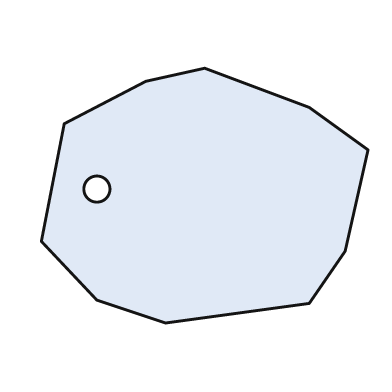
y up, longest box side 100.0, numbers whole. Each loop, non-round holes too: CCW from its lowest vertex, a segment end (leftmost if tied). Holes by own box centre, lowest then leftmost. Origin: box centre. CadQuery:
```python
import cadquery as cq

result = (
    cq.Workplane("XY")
    .moveTo(-12.0, -39.0)
    .lineTo(32.0, -33.0)
    .lineTo(43.0, -17.0)
    .lineTo(50.0, 14.0)
    .lineTo(32.0, 27.0)
    .lineTo(0.0, 39.0)
    .lineTo(-18.0, 35.0)
    .lineTo(-43.0, 22.0)
    .lineTo(-50.0, -14.0)
    .lineTo(-33.0, -32.0)
    .close()
    .moveTo(-33.0, 2.0)
    .circle(4.0)
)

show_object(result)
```